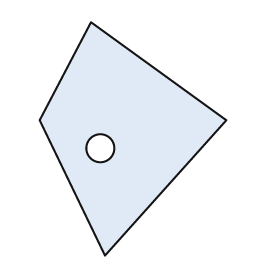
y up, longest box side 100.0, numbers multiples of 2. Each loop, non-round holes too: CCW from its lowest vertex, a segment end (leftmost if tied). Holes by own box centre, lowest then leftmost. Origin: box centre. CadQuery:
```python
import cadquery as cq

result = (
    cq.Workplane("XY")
    .moveTo(-12.0, -50.0)
    .lineTo(40.0, 8.0)
    .lineTo(-18.0, 50.0)
    .lineTo(-40.0, 8.0)
    .close()
    .moveTo(-14.0, -4.0)
    .circle(6.0)
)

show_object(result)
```